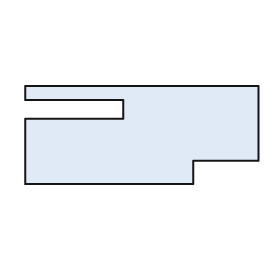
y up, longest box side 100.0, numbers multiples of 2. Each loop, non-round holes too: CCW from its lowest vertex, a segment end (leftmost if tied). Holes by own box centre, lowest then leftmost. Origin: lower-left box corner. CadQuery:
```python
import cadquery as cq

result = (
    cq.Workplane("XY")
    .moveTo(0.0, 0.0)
    .lineTo(72.0, 0.0)
    .lineTo(72.0, 10.0)
    .lineTo(100.0, 10.0)
    .lineTo(100.0, 42.0)
    .lineTo(0.0, 42.0)
    .lineTo(0.0, 36.0)
    .lineTo(42.0, 36.0)
    .lineTo(42.0, 28.0)
    .lineTo(0.0, 28.0)
    .close()
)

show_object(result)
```